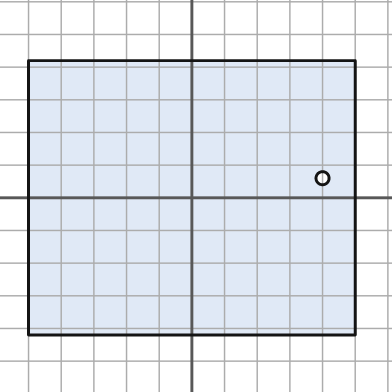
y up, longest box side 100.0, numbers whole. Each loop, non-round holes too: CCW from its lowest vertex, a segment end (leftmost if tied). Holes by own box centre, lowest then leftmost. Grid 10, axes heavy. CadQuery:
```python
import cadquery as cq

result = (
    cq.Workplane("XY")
    .moveTo(-50.0, -42.0)
    .lineTo(50.0, -42.0)
    .lineTo(50.0, 42.0)
    .lineTo(-50.0, 42.0)
    .close()
    .moveTo(40.0, 6.0)
    .circle(2.0)
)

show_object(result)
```